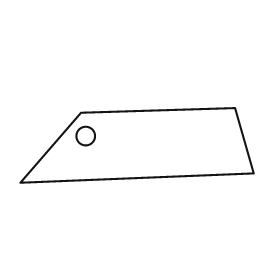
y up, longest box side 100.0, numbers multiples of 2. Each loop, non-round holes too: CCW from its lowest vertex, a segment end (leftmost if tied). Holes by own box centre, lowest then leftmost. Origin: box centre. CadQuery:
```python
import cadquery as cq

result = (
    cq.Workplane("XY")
    .moveTo(-50.0, -16.0)
    .lineTo(50.0, -12.0)
    .lineTo(42.0, 16.0)
    .lineTo(-24.0, 14.0)
    .close()
    .moveTo(-22.0, 4.0)
    .circle(4.0)
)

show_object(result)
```